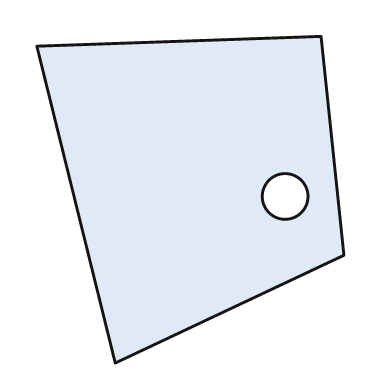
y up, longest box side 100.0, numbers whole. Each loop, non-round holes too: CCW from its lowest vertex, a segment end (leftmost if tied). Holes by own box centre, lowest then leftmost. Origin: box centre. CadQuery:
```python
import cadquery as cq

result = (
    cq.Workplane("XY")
    .moveTo(-23.0, -50.0)
    .lineTo(47.0, -17.0)
    .lineTo(40.0, 50.0)
    .lineTo(-47.0, 47.0)
    .close()
    .moveTo(29.0, 1.0)
    .circle(7.0)
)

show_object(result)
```